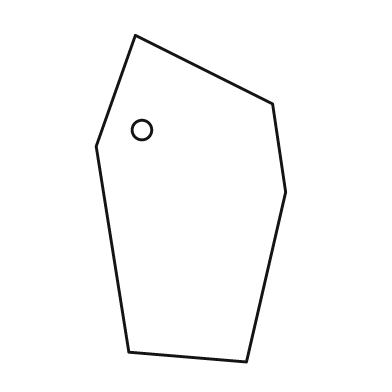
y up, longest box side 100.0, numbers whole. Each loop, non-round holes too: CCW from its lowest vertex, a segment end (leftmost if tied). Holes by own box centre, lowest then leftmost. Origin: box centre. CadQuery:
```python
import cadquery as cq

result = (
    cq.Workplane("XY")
    .moveTo(17.0, -50.0)
    .lineTo(29.0, 2.0)
    .lineTo(25.0, 29.0)
    .lineTo(-17.0, 50.0)
    .lineTo(-29.0, 16.0)
    .lineTo(-19.0, -47.0)
    .close()
    .moveTo(-15.0, 21.0)
    .circle(3.0)
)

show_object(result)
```